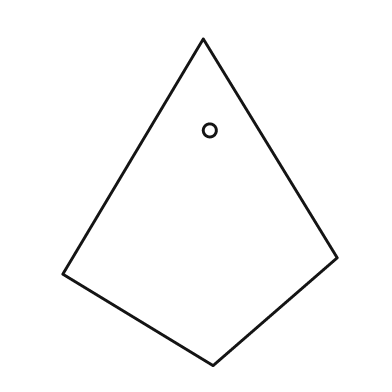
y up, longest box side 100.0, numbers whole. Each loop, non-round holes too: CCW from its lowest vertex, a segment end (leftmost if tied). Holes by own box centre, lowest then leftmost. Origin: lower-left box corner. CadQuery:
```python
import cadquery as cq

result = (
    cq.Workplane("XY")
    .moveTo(46.0, 0.0)
    .lineTo(84.0, 33.0)
    .lineTo(43.0, 100.0)
    .lineTo(0.0, 28.0)
    .close()
    .moveTo(45.0, 72.0)
    .circle(2.0)
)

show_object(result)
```